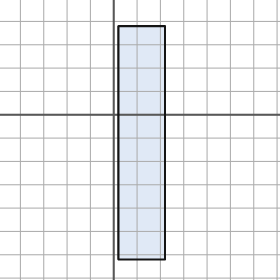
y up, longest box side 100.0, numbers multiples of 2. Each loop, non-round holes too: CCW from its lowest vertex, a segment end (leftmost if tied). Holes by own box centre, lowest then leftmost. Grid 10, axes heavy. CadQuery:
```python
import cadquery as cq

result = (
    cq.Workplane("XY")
    .moveTo(2.0, -62.0)
    .lineTo(22.0, -62.0)
    .lineTo(22.0, 38.0)
    .lineTo(2.0, 38.0)
    .close()
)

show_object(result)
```